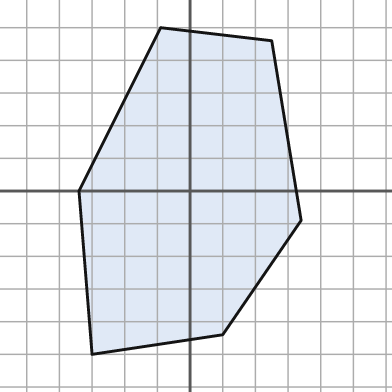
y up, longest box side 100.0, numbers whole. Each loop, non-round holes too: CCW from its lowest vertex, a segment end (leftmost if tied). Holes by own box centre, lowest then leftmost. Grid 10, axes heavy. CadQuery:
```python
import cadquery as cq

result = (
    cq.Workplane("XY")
    .moveTo(-30.0, -50.0)
    .lineTo(10.0, -44.0)
    .lineTo(34.0, -9.0)
    .lineTo(25.0, 46.0)
    .lineTo(-9.0, 50.0)
    .lineTo(-34.0, 0.0)
    .close()
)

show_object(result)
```